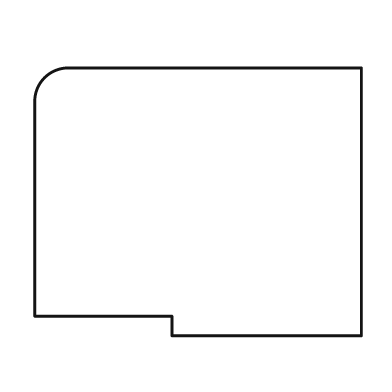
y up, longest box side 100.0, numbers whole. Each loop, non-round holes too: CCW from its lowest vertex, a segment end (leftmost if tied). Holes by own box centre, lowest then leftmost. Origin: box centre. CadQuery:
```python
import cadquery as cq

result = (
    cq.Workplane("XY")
    .moveTo(-8.0, -41.0)
    .lineTo(50.0, -41.0)
    .lineTo(50.0, 41.0)
    .lineTo(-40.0, 41.0)
    .threePointArc((-47.0, 38.0), (-50.0, 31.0))
    .lineTo(-50.0, -35.0)
    .lineTo(-8.0, -35.0)
    .close()
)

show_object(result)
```